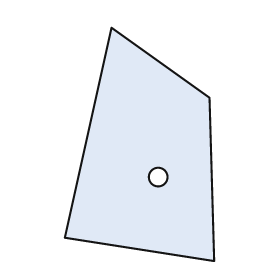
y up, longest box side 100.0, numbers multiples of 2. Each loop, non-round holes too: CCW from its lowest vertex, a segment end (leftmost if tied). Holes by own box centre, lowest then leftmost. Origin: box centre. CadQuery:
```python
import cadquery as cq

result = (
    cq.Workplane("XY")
    .moveTo(32.0, -50.0)
    .lineTo(30.0, 20.0)
    .lineTo(-12.0, 50.0)
    .lineTo(-32.0, -40.0)
    .close()
    .moveTo(8.0, -14.0)
    .circle(4.0)
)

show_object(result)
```